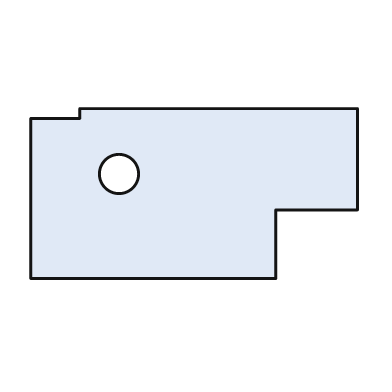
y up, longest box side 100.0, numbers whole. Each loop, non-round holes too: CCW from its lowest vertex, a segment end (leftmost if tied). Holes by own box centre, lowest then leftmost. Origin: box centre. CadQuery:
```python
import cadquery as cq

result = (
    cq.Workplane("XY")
    .moveTo(-50.0, -26.0)
    .lineTo(25.0, -26.0)
    .lineTo(25.0, -5.0)
    .lineTo(50.0, -5.0)
    .lineTo(50.0, 26.0)
    .lineTo(-35.0, 26.0)
    .lineTo(-35.0, 23.0)
    .lineTo(-50.0, 23.0)
    .close()
    .moveTo(-23.0, 6.0)
    .circle(6.0)
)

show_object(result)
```